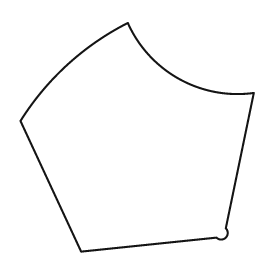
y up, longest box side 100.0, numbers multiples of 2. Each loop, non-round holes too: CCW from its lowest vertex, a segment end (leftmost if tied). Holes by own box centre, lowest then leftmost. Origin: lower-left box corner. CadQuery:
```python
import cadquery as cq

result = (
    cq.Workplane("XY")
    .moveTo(26.0, 0.0)
    .lineTo(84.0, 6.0)
    .threePointArc((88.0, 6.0), (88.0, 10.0))
    .lineTo(100.0, 68.0)
    .threePointArc((68.0, 74.0), (46.0, 98.0))
    .threePointArc((20.0, 80.0), (0.0, 56.0))
    .close()
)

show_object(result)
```